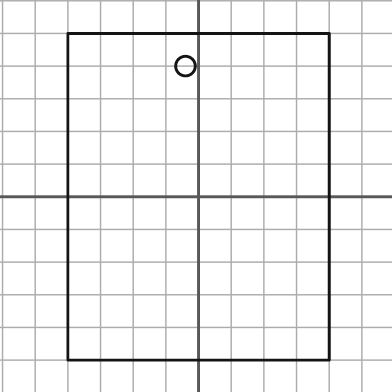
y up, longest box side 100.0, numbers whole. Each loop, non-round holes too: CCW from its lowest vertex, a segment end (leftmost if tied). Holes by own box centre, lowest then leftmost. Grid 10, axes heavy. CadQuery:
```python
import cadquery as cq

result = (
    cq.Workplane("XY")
    .moveTo(-40.0, -50.0)
    .lineTo(40.0, -50.0)
    .lineTo(40.0, 50.0)
    .lineTo(-40.0, 50.0)
    .close()
    .moveTo(-4.0, 40.0)
    .circle(3.0)
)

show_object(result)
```